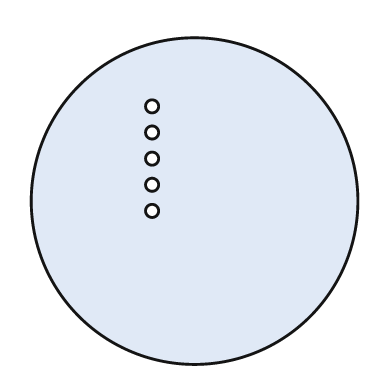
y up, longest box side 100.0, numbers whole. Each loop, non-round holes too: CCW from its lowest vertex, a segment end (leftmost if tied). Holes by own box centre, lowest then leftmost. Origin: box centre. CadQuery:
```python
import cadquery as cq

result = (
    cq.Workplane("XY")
    .moveTo(0.0, 0.0)
    .circle(50.0)
    .moveTo(-13.0, -3.0)
    .circle(2.0)
    .moveTo(-13.0, 5.0)
    .circle(2.0)
    .moveTo(-13.0, 13.0)
    .circle(2.0)
    .moveTo(-13.0, 21.0)
    .circle(2.0)
    .moveTo(-13.0, 29.0)
    .circle(2.0)
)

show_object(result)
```